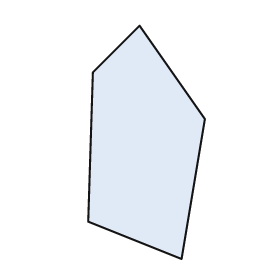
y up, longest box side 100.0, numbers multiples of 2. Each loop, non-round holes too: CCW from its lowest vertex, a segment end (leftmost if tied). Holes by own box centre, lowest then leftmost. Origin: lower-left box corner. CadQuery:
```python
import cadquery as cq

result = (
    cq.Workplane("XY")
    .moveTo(40.0, 0.0)
    .lineTo(50.0, 60.0)
    .lineTo(22.0, 100.0)
    .lineTo(2.0, 80.0)
    .lineTo(0.0, 16.0)
    .close()
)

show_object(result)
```